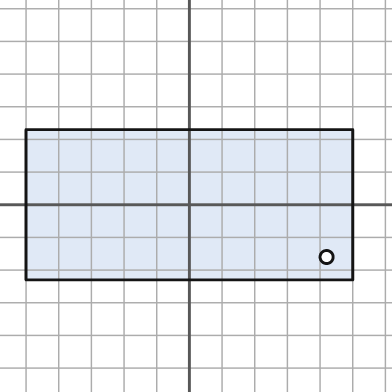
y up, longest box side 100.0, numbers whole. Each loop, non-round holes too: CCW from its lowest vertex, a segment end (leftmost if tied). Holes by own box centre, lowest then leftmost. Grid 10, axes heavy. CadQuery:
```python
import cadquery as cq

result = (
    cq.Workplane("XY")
    .moveTo(-50.0, -23.0)
    .lineTo(50.0, -23.0)
    .lineTo(50.0, 23.0)
    .lineTo(-50.0, 23.0)
    .close()
    .moveTo(42.0, -16.0)
    .circle(2.0)
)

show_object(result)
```